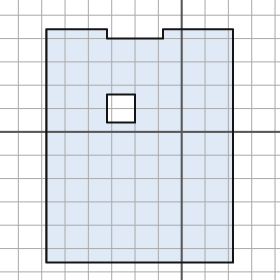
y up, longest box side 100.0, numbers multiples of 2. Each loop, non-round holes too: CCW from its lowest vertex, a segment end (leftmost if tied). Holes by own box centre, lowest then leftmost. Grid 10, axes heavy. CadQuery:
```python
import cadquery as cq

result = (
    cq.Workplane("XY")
    .moveTo(-58.0, -56.0)
    .lineTo(22.0, -56.0)
    .lineTo(22.0, 44.0)
    .lineTo(-8.0, 44.0)
    .lineTo(-8.0, 40.0)
    .lineTo(-32.0, 40.0)
    .lineTo(-32.0, 44.0)
    .lineTo(-58.0, 44.0)
    .close()
    .moveTo(-32.0, 4.0)
    .lineTo(-20.0, 4.0)
    .lineTo(-20.0, 16.0)
    .lineTo(-32.0, 16.0)
    .close()
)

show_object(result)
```